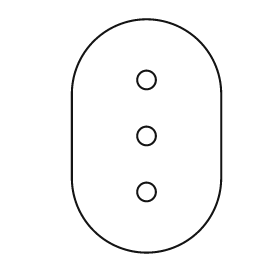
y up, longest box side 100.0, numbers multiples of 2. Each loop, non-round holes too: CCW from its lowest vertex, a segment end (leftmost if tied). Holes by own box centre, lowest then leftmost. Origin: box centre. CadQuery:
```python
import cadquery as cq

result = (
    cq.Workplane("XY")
    .moveTo(-32.0, -18.0)
    .threePointArc((0.0, -50.0), (32.0, -18.0))
    .lineTo(32.0, 18.0)
    .threePointArc((0.0, 50.0), (-32.0, 18.0))
    .close()
    .moveTo(0.0, -24.0)
    .circle(4.0)
    .moveTo(0.0, 0.0)
    .circle(4.0)
    .moveTo(0.0, 24.0)
    .circle(4.0)
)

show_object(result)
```